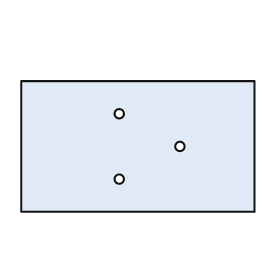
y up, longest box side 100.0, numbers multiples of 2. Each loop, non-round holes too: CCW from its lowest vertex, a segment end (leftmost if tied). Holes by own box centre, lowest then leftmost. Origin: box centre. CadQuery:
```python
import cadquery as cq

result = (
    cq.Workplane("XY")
    .moveTo(-50.0, -28.0)
    .lineTo(50.0, -28.0)
    .lineTo(50.0, 28.0)
    .lineTo(-50.0, 28.0)
    .close()
    .moveTo(-8.0, -14.0)
    .circle(2.0)
    .moveTo(18.0, 0.0)
    .circle(2.0)
    .moveTo(-8.0, 14.0)
    .circle(2.0)
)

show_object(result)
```